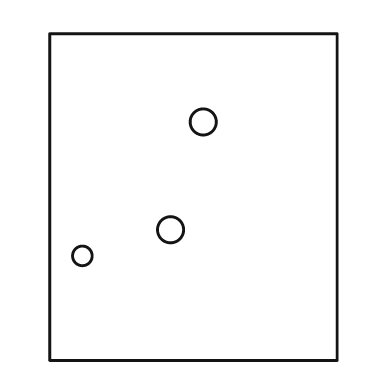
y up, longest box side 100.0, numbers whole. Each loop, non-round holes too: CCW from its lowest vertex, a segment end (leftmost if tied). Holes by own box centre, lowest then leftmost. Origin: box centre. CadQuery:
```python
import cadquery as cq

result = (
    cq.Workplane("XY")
    .moveTo(-44.0, -50.0)
    .lineTo(44.0, -50.0)
    .lineTo(44.0, 50.0)
    .lineTo(-44.0, 50.0)
    .close()
    .moveTo(-34.0, -18.0)
    .circle(3.0)
    .moveTo(-7.0, -10.0)
    .circle(4.0)
    .moveTo(3.0, 23.0)
    .circle(4.0)
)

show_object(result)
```